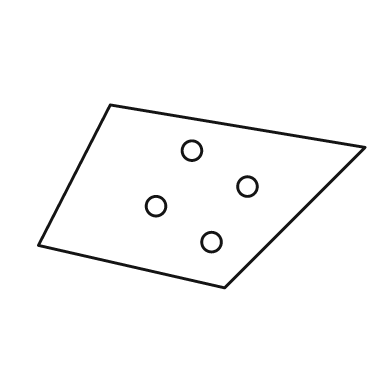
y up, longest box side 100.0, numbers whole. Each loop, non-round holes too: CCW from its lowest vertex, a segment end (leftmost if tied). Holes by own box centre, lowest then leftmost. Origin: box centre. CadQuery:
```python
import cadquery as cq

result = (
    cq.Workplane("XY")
    .moveTo(7.0, -28.0)
    .lineTo(50.0, 15.0)
    .lineTo(-28.0, 28.0)
    .lineTo(-50.0, -15.0)
    .close()
    .moveTo(3.0, -14.0)
    .circle(3.0)
    .moveTo(-14.0, -3.0)
    .circle(3.0)
    .moveTo(14.0, 3.0)
    .circle(3.0)
    .moveTo(-3.0, 14.0)
    .circle(3.0)
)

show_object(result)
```